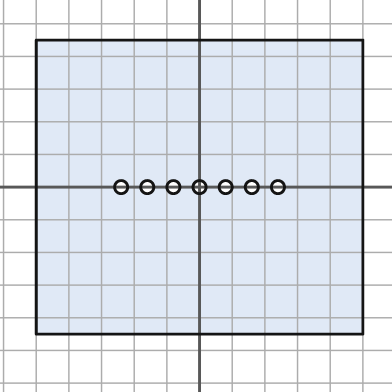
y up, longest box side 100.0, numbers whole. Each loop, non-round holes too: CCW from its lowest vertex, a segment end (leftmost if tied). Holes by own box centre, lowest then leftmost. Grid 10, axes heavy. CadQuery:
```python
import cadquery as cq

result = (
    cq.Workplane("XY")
    .moveTo(-50.0, -45.0)
    .lineTo(50.0, -45.0)
    .lineTo(50.0, 45.0)
    .lineTo(-50.0, 45.0)
    .close()
    .moveTo(-24.0, 0.0)
    .circle(2.0)
    .moveTo(-16.0, 0.0)
    .circle(2.0)
    .moveTo(-8.0, 0.0)
    .circle(2.0)
    .moveTo(0.0, 0.0)
    .circle(2.0)
    .moveTo(8.0, 0.0)
    .circle(2.0)
    .moveTo(16.0, 0.0)
    .circle(2.0)
    .moveTo(24.0, 0.0)
    .circle(2.0)
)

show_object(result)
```